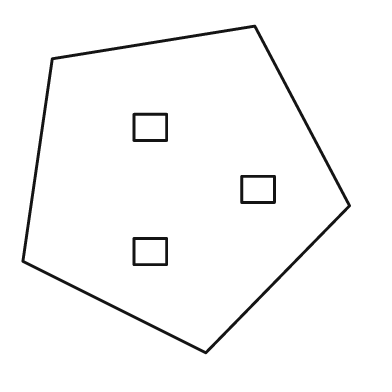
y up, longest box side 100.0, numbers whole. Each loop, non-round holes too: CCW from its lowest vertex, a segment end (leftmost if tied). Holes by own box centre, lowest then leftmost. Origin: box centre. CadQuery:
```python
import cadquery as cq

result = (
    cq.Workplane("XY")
    .moveTo(6.0, -50.0)
    .lineTo(50.0, -5.0)
    .lineTo(21.0, 50.0)
    .lineTo(-41.0, 40.0)
    .lineTo(-50.0, -22.0)
    .close()
    .moveTo(-16.0, -23.0)
    .lineTo(-6.0, -23.0)
    .lineTo(-6.0, -15.0)
    .lineTo(-16.0, -15.0)
    .close()
    .moveTo(17.0, -4.0)
    .lineTo(27.0, -4.0)
    .lineTo(27.0, 4.0)
    .lineTo(17.0, 4.0)
    .close()
    .moveTo(-16.0, 15.0)
    .lineTo(-6.0, 15.0)
    .lineTo(-6.0, 23.0)
    .lineTo(-16.0, 23.0)
    .close()
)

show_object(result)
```